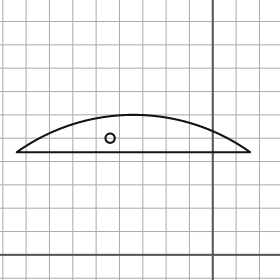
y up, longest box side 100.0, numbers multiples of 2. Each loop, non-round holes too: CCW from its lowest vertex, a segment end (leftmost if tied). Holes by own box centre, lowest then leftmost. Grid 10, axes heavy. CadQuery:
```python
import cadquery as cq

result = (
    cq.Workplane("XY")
    .moveTo(-84.0, 44.0)
    .lineTo(16.0, 44.0)
    .threePointArc((-34.0, 60.0), (-84.0, 44.0))
    .close()
    .moveTo(-44.0, 50.0)
    .circle(2.0)
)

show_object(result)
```